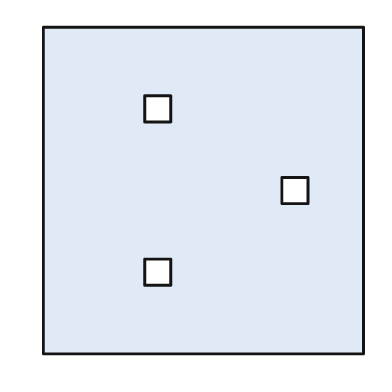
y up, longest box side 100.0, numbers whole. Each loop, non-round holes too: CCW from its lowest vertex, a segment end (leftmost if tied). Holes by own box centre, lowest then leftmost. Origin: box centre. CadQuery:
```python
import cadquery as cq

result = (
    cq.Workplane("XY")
    .moveTo(-49.0, -50.0)
    .lineTo(49.0, -50.0)
    .lineTo(49.0, 50.0)
    .lineTo(-49.0, 50.0)
    .close()
    .moveTo(-18.0, -29.0)
    .lineTo(-10.0, -29.0)
    .lineTo(-10.0, -21.0)
    .lineTo(-18.0, -21.0)
    .close()
    .moveTo(24.0, -4.0)
    .lineTo(32.0, -4.0)
    .lineTo(32.0, 4.0)
    .lineTo(24.0, 4.0)
    .close()
    .moveTo(-18.0, 21.0)
    .lineTo(-10.0, 21.0)
    .lineTo(-10.0, 29.0)
    .lineTo(-18.0, 29.0)
    .close()
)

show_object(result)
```